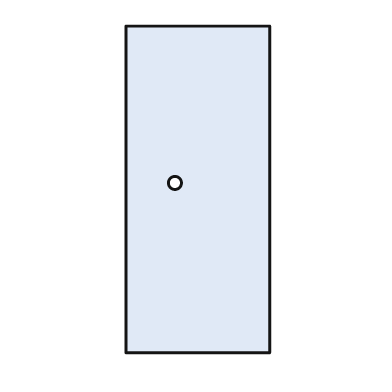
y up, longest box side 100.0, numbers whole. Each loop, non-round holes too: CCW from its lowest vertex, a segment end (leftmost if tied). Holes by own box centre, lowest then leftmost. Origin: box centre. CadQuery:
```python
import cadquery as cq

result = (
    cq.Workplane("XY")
    .moveTo(-22.0, -50.0)
    .lineTo(22.0, -50.0)
    .lineTo(22.0, 50.0)
    .lineTo(-22.0, 50.0)
    .close()
    .moveTo(-7.0, 2.0)
    .circle(2.0)
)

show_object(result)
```